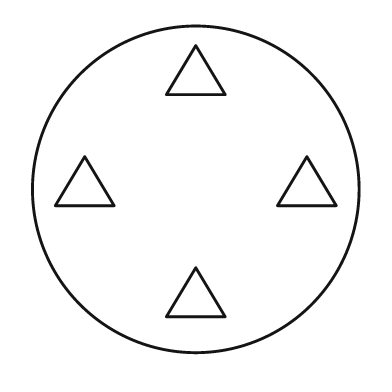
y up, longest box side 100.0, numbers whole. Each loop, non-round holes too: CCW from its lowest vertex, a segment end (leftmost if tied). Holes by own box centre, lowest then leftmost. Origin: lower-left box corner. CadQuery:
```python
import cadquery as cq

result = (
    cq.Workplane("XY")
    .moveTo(50.0, 50.0)
    .circle(50.0)
    .moveTo(41.0, 11.0)
    .lineTo(59.0, 11.0)
    .lineTo(50.0, 26.0)
    .close()
    .moveTo(7.0, 45.0)
    .lineTo(25.0, 45.0)
    .lineTo(16.0, 60.0)
    .close()
    .moveTo(75.0, 45.0)
    .lineTo(93.0, 45.0)
    .lineTo(84.0, 60.0)
    .close()
    .moveTo(41.0, 79.0)
    .lineTo(59.0, 79.0)
    .lineTo(50.0, 94.0)
    .close()
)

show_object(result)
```